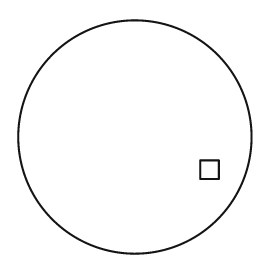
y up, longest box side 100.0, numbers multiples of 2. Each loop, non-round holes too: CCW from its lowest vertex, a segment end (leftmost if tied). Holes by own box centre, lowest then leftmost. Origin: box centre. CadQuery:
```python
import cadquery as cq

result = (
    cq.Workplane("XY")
    .moveTo(0.0, 0.0)
    .circle(50.0)
    .moveTo(28.0, -18.0)
    .lineTo(36.0, -18.0)
    .lineTo(36.0, -10.0)
    .lineTo(28.0, -10.0)
    .close()
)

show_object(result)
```